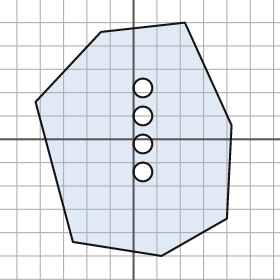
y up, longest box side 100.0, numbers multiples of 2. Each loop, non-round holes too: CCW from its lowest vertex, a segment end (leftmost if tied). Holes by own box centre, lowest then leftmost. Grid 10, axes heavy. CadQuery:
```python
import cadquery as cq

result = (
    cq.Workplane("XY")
    .moveTo(12.0, -50.0)
    .lineTo(40.0, -34.0)
    .lineTo(42.0, 6.0)
    .lineTo(22.0, 50.0)
    .lineTo(-14.0, 46.0)
    .lineTo(-42.0, 16.0)
    .lineTo(-26.0, -44.0)
    .close()
    .moveTo(4.0, -14.0)
    .circle(4.0)
    .moveTo(4.0, -2.0)
    .circle(4.0)
    .moveTo(4.0, 10.0)
    .circle(4.0)
    .moveTo(4.0, 22.0)
    .circle(4.0)
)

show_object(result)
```